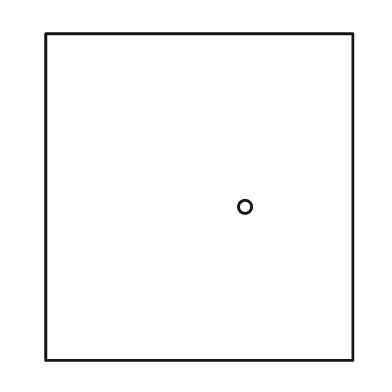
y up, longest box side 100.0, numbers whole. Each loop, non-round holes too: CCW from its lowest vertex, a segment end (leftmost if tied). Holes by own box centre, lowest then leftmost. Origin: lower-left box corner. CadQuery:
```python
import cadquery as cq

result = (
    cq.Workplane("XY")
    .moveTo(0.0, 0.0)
    .lineTo(94.0, 0.0)
    .lineTo(94.0, 100.0)
    .lineTo(0.0, 100.0)
    .close()
    .moveTo(61.0, 47.0)
    .circle(2.0)
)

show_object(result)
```